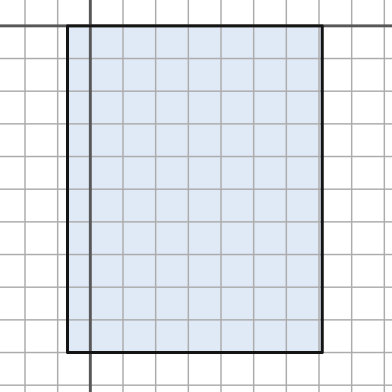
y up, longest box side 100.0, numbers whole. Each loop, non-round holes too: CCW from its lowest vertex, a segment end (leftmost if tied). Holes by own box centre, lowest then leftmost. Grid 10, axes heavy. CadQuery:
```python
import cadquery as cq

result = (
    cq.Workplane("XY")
    .moveTo(-7.0, -100.0)
    .lineTo(71.0, -100.0)
    .lineTo(71.0, 0.0)
    .lineTo(-7.0, 0.0)
    .close()
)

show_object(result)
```